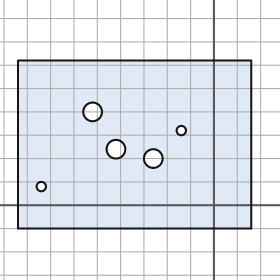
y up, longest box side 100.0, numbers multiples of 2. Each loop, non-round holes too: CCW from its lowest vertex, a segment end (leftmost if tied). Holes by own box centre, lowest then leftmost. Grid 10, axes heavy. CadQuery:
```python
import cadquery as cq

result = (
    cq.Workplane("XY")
    .moveTo(-84.0, -10.0)
    .lineTo(16.0, -10.0)
    .lineTo(16.0, 62.0)
    .lineTo(-84.0, 62.0)
    .close()
    .moveTo(-74.0, 8.0)
    .circle(2.0)
    .moveTo(-26.0, 20.0)
    .circle(4.0)
    .moveTo(-42.0, 24.0)
    .circle(4.0)
    .moveTo(-14.0, 32.0)
    .circle(2.0)
    .moveTo(-52.0, 40.0)
    .circle(4.0)
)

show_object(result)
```